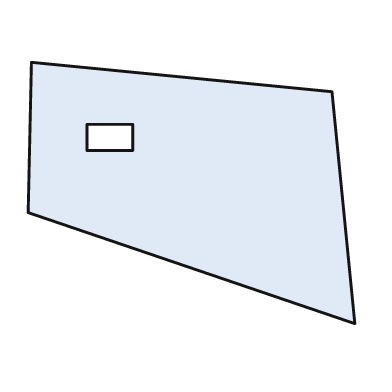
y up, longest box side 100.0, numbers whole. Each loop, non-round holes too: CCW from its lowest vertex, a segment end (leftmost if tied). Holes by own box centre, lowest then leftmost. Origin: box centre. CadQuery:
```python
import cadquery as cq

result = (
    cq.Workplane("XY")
    .moveTo(50.0, -40.0)
    .lineTo(43.0, 31.0)
    .lineTo(-49.0, 40.0)
    .lineTo(-50.0, -6.0)
    .close()
    .moveTo(-32.0, 13.0)
    .lineTo(-18.0, 13.0)
    .lineTo(-18.0, 21.0)
    .lineTo(-32.0, 21.0)
    .close()
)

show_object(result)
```